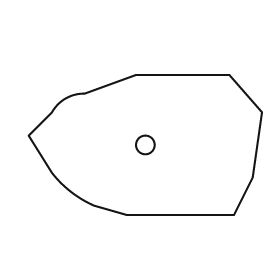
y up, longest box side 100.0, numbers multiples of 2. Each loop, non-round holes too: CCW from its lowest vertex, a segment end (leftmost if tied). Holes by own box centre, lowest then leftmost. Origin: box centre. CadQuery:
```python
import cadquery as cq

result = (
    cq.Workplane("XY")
    .moveTo(-8.0, -30.0)
    .lineTo(38.0, -30.0)
    .lineTo(46.0, -14.0)
    .lineTo(50.0, 14.0)
    .lineTo(36.0, 30.0)
    .lineTo(-4.0, 30.0)
    .lineTo(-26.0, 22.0)
    .threePointArc((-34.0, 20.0), (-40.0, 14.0))
    .lineTo(-50.0, 4.0)
    .lineTo(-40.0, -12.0)
    .threePointArc((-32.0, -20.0), (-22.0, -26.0))
    .close()
    .moveTo(0.0, 0.0)
    .circle(4.0)
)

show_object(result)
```